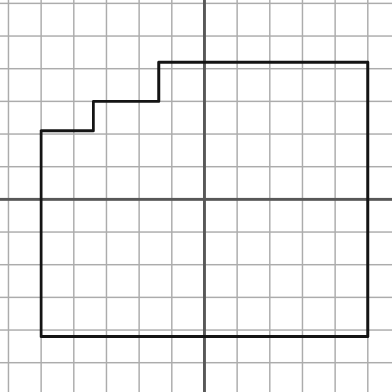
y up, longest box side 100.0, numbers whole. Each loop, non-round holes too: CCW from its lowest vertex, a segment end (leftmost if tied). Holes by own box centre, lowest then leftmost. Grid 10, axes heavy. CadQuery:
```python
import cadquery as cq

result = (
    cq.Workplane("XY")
    .moveTo(-50.0, -42.0)
    .lineTo(50.0, -42.0)
    .lineTo(50.0, 42.0)
    .lineTo(-14.0, 42.0)
    .lineTo(-14.0, 30.0)
    .lineTo(-34.0, 30.0)
    .lineTo(-34.0, 21.0)
    .lineTo(-50.0, 21.0)
    .close()
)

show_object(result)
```